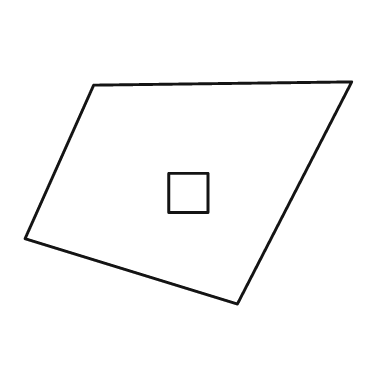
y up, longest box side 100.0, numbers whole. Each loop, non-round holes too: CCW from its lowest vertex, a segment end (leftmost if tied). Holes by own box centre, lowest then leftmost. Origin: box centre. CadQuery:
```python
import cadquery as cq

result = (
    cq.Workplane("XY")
    .moveTo(15.0, -34.0)
    .lineTo(50.0, 34.0)
    .lineTo(-29.0, 33.0)
    .lineTo(-50.0, -14.0)
    .close()
    .moveTo(-6.0, -6.0)
    .lineTo(6.0, -6.0)
    .lineTo(6.0, 6.0)
    .lineTo(-6.0, 6.0)
    .close()
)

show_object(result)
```